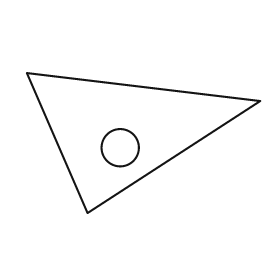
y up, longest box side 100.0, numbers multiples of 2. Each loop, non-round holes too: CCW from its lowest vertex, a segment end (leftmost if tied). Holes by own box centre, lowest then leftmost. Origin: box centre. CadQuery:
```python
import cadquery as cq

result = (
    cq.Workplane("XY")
    .moveTo(-24.0, -30.0)
    .lineTo(50.0, 18.0)
    .lineTo(-50.0, 30.0)
    .close()
    .moveTo(-10.0, -2.0)
    .circle(8.0)
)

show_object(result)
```